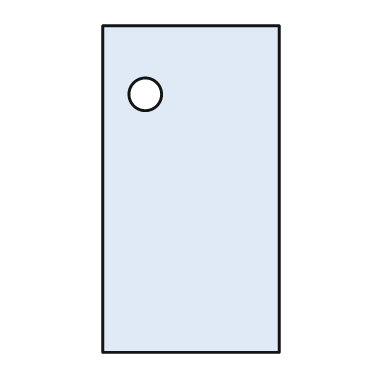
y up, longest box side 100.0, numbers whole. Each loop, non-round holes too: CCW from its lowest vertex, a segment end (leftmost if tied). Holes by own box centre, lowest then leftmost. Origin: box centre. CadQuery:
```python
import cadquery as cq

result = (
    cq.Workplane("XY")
    .moveTo(-27.0, -50.0)
    .lineTo(27.0, -50.0)
    .lineTo(27.0, 50.0)
    .lineTo(-27.0, 50.0)
    .close()
    .moveTo(-14.0, 29.0)
    .circle(5.0)
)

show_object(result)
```